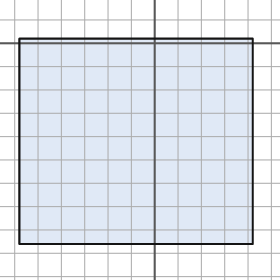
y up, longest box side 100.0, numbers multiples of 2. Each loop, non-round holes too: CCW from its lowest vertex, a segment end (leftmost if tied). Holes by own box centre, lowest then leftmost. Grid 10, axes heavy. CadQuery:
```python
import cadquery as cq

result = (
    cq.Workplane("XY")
    .moveTo(-58.0, -86.0)
    .lineTo(42.0, -86.0)
    .lineTo(42.0, 2.0)
    .lineTo(-58.0, 2.0)
    .close()
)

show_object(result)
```